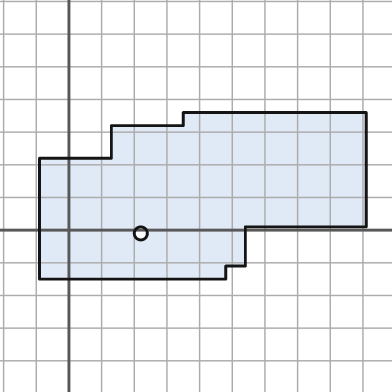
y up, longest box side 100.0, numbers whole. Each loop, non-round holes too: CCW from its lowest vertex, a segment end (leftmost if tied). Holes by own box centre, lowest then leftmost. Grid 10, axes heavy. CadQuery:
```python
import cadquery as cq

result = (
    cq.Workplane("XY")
    .moveTo(-9.0, -15.0)
    .lineTo(48.0, -15.0)
    .lineTo(48.0, -11.0)
    .lineTo(54.0, -11.0)
    .lineTo(54.0, 1.0)
    .lineTo(91.0, 1.0)
    .lineTo(91.0, 36.0)
    .lineTo(35.0, 36.0)
    .lineTo(35.0, 32.0)
    .lineTo(13.0, 32.0)
    .lineTo(13.0, 22.0)
    .lineTo(-9.0, 22.0)
    .close()
    .moveTo(22.0, -1.0)
    .circle(2.0)
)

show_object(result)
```